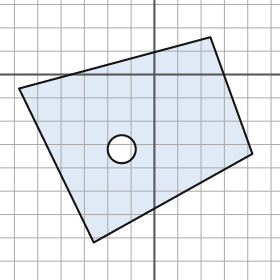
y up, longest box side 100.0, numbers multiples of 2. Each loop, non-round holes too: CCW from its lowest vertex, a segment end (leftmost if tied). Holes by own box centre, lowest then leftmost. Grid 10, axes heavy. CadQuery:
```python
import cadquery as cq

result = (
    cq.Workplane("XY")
    .moveTo(-26.0, -72.0)
    .lineTo(42.0, -34.0)
    .lineTo(24.0, 16.0)
    .lineTo(-58.0, -6.0)
    .close()
    .moveTo(-14.0, -32.0)
    .circle(6.0)
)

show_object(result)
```